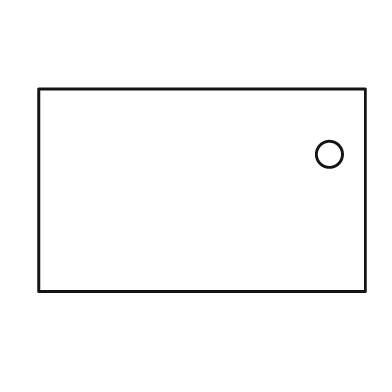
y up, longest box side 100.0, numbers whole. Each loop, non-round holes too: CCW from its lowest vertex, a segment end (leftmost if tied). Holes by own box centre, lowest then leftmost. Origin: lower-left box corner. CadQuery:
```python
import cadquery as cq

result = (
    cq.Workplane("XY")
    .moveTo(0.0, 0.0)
    .lineTo(100.0, 0.0)
    .lineTo(100.0, 62.0)
    .lineTo(0.0, 62.0)
    .close()
    .moveTo(89.0, 42.0)
    .circle(4.0)
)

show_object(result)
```